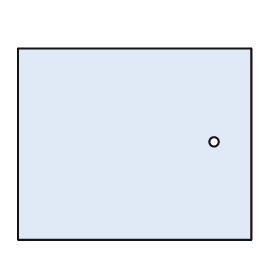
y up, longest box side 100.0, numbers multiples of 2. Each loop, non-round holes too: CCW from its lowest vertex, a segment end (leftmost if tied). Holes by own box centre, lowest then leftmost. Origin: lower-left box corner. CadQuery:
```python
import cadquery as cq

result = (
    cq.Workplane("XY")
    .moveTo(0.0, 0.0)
    .lineTo(100.0, 0.0)
    .lineTo(100.0, 82.0)
    .lineTo(0.0, 82.0)
    .close()
    .moveTo(84.0, 42.0)
    .circle(2.0)
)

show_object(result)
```